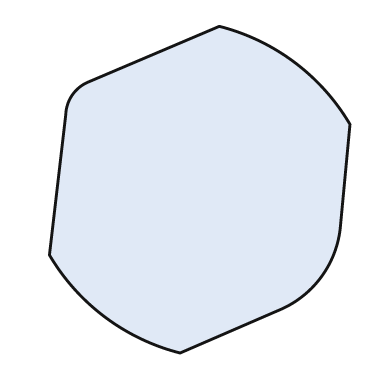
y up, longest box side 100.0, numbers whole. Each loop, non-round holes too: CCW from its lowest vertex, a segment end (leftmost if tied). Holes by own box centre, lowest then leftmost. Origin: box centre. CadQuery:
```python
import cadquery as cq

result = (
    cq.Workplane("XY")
    .moveTo(-6.0, -50.0)
    .lineTo(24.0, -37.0)
    .threePointArc((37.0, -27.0), (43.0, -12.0))
    .lineTo(46.0, 20.0)
    .threePointArc((29.0, 39.0), (6.0, 50.0))
    .lineTo(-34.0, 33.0)
    .threePointArc((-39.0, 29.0), (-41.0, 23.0))
    .lineTo(-46.0, -20.0)
    .threePointArc((-29.0, -39.0), (-6.0, -50.0))
    .close()
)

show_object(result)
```